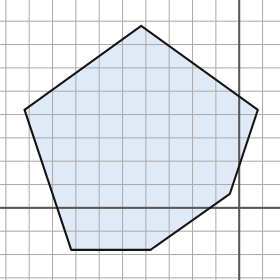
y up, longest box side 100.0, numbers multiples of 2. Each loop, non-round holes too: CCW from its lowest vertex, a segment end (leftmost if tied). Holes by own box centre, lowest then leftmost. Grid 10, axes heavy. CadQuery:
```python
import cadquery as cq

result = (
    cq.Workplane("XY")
    .moveTo(-72.0, -18.0)
    .lineTo(-38.0, -18.0)
    .lineTo(-4.0, 6.0)
    .lineTo(8.0, 42.0)
    .lineTo(-42.0, 78.0)
    .lineTo(-92.0, 42.0)
    .close()
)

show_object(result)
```